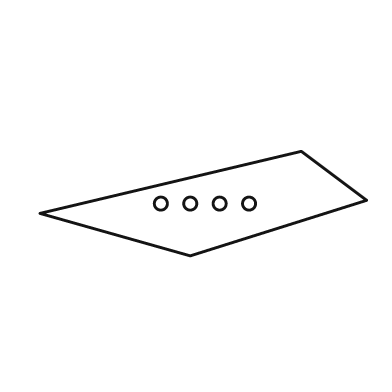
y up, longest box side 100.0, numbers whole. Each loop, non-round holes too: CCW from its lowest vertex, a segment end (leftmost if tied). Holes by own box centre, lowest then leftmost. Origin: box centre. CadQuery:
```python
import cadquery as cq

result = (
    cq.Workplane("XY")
    .moveTo(-4.0, -16.0)
    .lineTo(50.0, 1.0)
    .lineTo(30.0, 16.0)
    .lineTo(-50.0, -3.0)
    .close()
    .moveTo(-13.0, 0.0)
    .circle(2.0)
    .moveTo(-4.0, 0.0)
    .circle(2.0)
    .moveTo(5.0, 0.0)
    .circle(2.0)
    .moveTo(14.0, 0.0)
    .circle(2.0)
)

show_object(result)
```